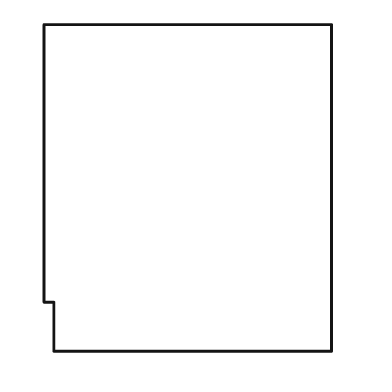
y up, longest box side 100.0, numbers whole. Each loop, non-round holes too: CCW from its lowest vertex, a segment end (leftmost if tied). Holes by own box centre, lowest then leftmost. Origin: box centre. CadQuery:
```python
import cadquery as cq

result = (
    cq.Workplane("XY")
    .moveTo(-41.0, -50.0)
    .lineTo(44.0, -50.0)
    .lineTo(44.0, 50.0)
    .lineTo(-44.0, 50.0)
    .lineTo(-44.0, -35.0)
    .lineTo(-41.0, -35.0)
    .close()
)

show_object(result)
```